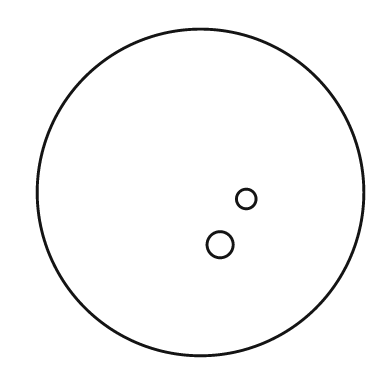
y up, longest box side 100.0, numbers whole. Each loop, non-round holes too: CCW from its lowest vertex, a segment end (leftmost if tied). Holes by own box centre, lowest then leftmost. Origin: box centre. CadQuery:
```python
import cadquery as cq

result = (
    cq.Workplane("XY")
    .moveTo(0.0, 0.0)
    .circle(50.0)
    .moveTo(6.0, -16.0)
    .circle(4.0)
    .moveTo(14.0, -2.0)
    .circle(3.0)
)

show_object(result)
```